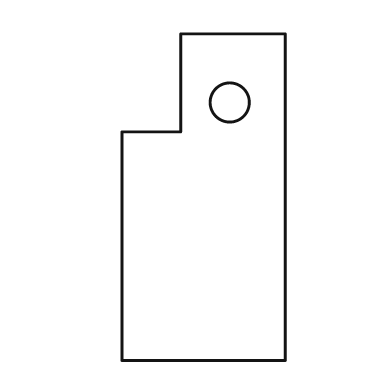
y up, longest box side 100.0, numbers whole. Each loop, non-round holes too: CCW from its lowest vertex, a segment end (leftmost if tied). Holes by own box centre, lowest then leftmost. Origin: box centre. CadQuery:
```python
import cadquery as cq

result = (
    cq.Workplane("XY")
    .moveTo(-25.0, -50.0)
    .lineTo(25.0, -50.0)
    .lineTo(25.0, 50.0)
    .lineTo(-7.0, 50.0)
    .lineTo(-7.0, 20.0)
    .lineTo(-25.0, 20.0)
    .close()
    .moveTo(8.0, 29.0)
    .circle(6.0)
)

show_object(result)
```